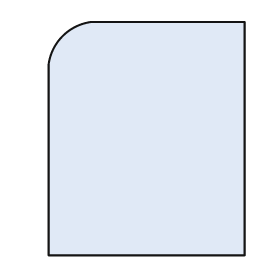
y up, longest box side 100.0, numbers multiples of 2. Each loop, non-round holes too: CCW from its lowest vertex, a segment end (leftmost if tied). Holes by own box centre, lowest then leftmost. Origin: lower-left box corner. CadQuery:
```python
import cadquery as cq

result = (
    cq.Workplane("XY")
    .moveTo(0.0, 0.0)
    .lineTo(84.0, 0.0)
    .lineTo(84.0, 100.0)
    .lineTo(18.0, 100.0)
    .threePointArc((6.0, 94.0), (0.0, 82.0))
    .close()
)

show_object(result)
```